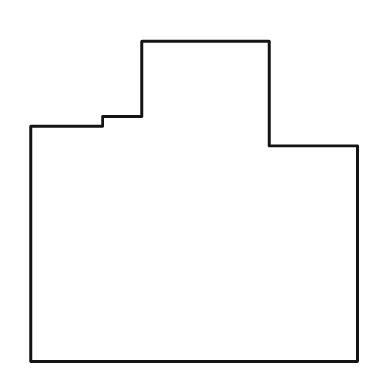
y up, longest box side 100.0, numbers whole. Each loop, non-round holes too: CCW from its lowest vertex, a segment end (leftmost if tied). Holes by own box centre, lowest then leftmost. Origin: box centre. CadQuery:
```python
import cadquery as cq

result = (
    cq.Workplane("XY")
    .moveTo(-50.0, -49.0)
    .lineTo(50.0, -49.0)
    .lineTo(50.0, 17.0)
    .lineTo(23.0, 17.0)
    .lineTo(23.0, 49.0)
    .lineTo(-16.0, 49.0)
    .lineTo(-16.0, 26.0)
    .lineTo(-28.0, 26.0)
    .lineTo(-28.0, 23.0)
    .lineTo(-50.0, 23.0)
    .close()
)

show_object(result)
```